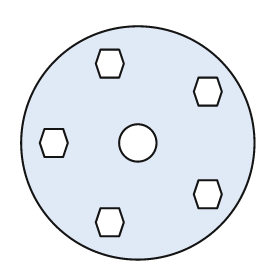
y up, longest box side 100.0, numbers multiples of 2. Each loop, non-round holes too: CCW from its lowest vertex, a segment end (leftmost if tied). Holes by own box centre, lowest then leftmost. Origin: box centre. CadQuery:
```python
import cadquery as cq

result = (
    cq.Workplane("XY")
    .moveTo(0.0, 0.0)
    .circle(50.0)
    .moveTo(-16.0, -40.0)
    .lineTo(-8.0, -40.0)
    .lineTo(-6.0, -34.0)
    .lineTo(-8.0, -28.0)
    .lineTo(-16.0, -28.0)
    .lineTo(-18.0, -34.0)
    .close()
    .moveTo(26.0, -28.0)
    .lineTo(34.0, -28.0)
    .lineTo(36.0, -22.0)
    .lineTo(34.0, -16.0)
    .lineTo(26.0, -16.0)
    .lineTo(24.0, -22.0)
    .close()
    .moveTo(-40.0, -6.0)
    .lineTo(-32.0, -6.0)
    .lineTo(-30.0, 0.0)
    .lineTo(-32.0, 6.0)
    .lineTo(-40.0, 6.0)
    .lineTo(-42.0, 0.0)
    .close()
    .moveTo(0.0, 0.0)
    .circle(8.0)
    .moveTo(26.0, 16.0)
    .lineTo(34.0, 16.0)
    .lineTo(36.0, 22.0)
    .lineTo(34.0, 28.0)
    .lineTo(26.0, 28.0)
    .lineTo(24.0, 22.0)
    .close()
    .moveTo(-16.0, 28.0)
    .lineTo(-8.0, 28.0)
    .lineTo(-6.0, 34.0)
    .lineTo(-8.0, 40.0)
    .lineTo(-16.0, 40.0)
    .lineTo(-18.0, 34.0)
    .close()
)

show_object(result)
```